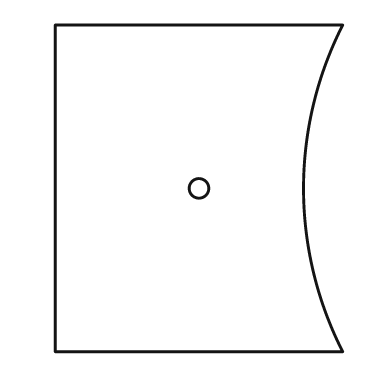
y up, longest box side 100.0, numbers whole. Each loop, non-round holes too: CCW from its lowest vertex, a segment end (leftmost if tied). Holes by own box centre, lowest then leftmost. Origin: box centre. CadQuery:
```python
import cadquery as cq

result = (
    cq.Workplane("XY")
    .moveTo(-44.0, -50.0)
    .lineTo(44.0, -50.0)
    .threePointArc((32.0, 0.0), (44.0, 50.0))
    .lineTo(-44.0, 50.0)
    .close()
    .moveTo(0.0, 0.0)
    .circle(3.0)
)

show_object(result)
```